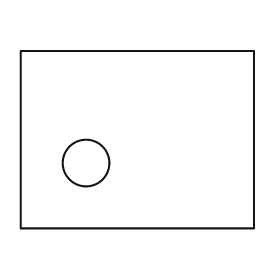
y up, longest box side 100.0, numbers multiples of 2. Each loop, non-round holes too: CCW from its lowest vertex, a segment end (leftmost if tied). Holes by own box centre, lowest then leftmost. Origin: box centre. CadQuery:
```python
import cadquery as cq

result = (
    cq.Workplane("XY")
    .moveTo(-50.0, -38.0)
    .lineTo(50.0, -38.0)
    .lineTo(50.0, 38.0)
    .lineTo(-50.0, 38.0)
    .close()
    .moveTo(-22.0, -10.0)
    .circle(10.0)
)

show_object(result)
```